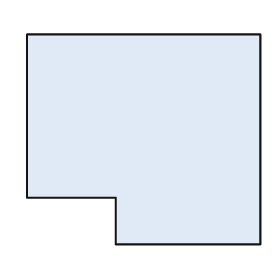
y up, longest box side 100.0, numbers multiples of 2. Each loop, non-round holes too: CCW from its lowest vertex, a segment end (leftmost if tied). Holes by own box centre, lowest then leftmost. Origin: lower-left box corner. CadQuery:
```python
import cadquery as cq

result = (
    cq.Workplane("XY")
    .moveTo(38.0, 0.0)
    .lineTo(100.0, 0.0)
    .lineTo(100.0, 90.0)
    .lineTo(0.0, 90.0)
    .lineTo(0.0, 20.0)
    .lineTo(38.0, 20.0)
    .close()
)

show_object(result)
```